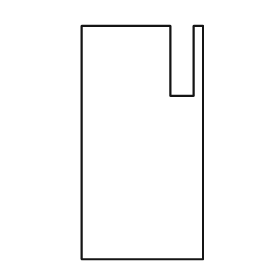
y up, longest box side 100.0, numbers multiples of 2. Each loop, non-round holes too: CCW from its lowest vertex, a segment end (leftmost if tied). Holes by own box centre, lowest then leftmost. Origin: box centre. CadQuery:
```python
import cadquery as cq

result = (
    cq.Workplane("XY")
    .moveTo(-26.0, -50.0)
    .lineTo(26.0, -50.0)
    .lineTo(26.0, 50.0)
    .lineTo(22.0, 50.0)
    .lineTo(22.0, 20.0)
    .lineTo(12.0, 20.0)
    .lineTo(12.0, 50.0)
    .lineTo(-26.0, 50.0)
    .close()
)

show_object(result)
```